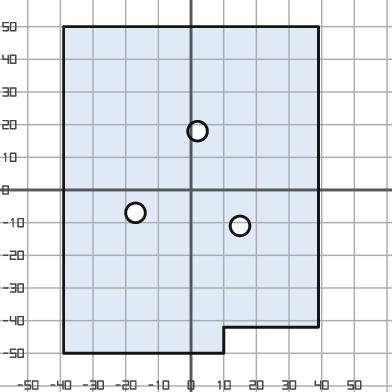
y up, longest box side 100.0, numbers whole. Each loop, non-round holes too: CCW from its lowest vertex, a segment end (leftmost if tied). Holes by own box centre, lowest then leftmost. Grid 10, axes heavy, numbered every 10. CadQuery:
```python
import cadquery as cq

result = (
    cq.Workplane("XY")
    .moveTo(-39.0, -50.0)
    .lineTo(10.0, -50.0)
    .lineTo(10.0, -42.0)
    .lineTo(39.0, -42.0)
    .lineTo(39.0, 50.0)
    .lineTo(-39.0, 50.0)
    .close()
    .moveTo(15.0, -11.0)
    .circle(3.0)
    .moveTo(-17.0, -7.0)
    .circle(3.0)
    .moveTo(2.0, 18.0)
    .circle(3.0)
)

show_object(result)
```